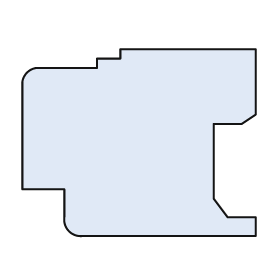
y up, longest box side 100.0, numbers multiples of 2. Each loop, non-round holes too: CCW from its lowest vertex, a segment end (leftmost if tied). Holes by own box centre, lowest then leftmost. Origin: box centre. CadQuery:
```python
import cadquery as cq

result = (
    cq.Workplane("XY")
    .moveTo(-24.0, -40.0)
    .lineTo(50.0, -40.0)
    .lineTo(50.0, -32.0)
    .lineTo(38.0, -32.0)
    .lineTo(32.0, -24.0)
    .lineTo(32.0, 8.0)
    .lineTo(44.0, 8.0)
    .lineTo(50.0, 12.0)
    .lineTo(50.0, 40.0)
    .lineTo(-8.0, 40.0)
    .lineTo(-8.0, 36.0)
    .lineTo(-18.0, 36.0)
    .lineTo(-18.0, 32.0)
    .lineTo(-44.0, 32.0)
    .threePointArc((-48.0, 30.0), (-50.0, 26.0))
    .lineTo(-50.0, -20.0)
    .lineTo(-32.0, -20.0)
    .lineTo(-32.0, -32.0)
    .threePointArc((-30.0, -38.0), (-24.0, -40.0))
    .close()
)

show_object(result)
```